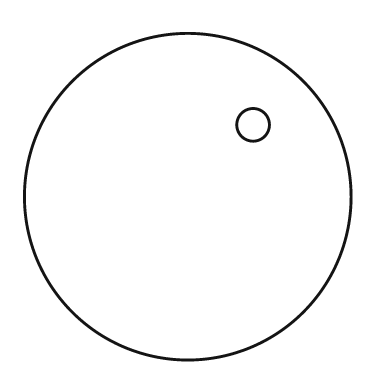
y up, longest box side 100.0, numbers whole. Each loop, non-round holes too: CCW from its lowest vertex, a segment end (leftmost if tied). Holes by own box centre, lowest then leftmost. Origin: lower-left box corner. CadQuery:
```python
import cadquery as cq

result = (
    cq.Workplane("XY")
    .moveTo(50.0, 50.0)
    .circle(50.0)
    .moveTo(70.0, 72.0)
    .circle(5.0)
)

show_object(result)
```